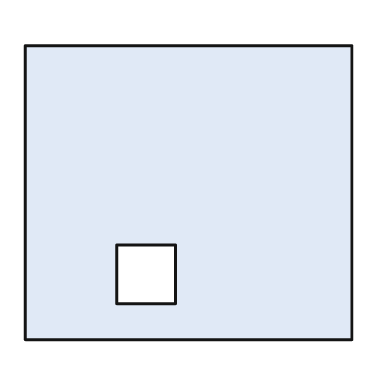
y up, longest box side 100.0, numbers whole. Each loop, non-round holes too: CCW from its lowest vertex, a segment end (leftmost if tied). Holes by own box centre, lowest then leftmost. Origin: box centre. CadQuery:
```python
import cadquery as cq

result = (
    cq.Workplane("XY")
    .moveTo(-50.0, -45.0)
    .lineTo(50.0, -45.0)
    .lineTo(50.0, 45.0)
    .lineTo(-50.0, 45.0)
    .close()
    .moveTo(-22.0, -34.0)
    .lineTo(-4.0, -34.0)
    .lineTo(-4.0, -16.0)
    .lineTo(-22.0, -16.0)
    .close()
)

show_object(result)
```